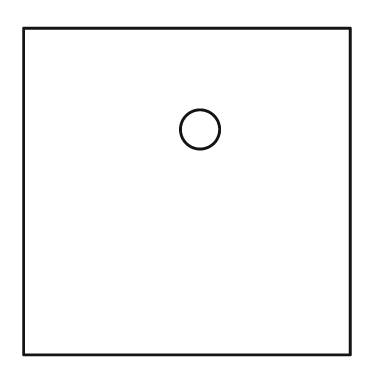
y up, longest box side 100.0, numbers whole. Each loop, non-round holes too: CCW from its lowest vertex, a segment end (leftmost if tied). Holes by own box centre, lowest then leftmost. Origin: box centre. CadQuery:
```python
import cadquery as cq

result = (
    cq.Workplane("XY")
    .moveTo(-50.0, -50.0)
    .lineTo(50.0, -50.0)
    .lineTo(50.0, 50.0)
    .lineTo(-50.0, 50.0)
    .close()
    .moveTo(4.0, 19.0)
    .circle(6.0)
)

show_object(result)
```